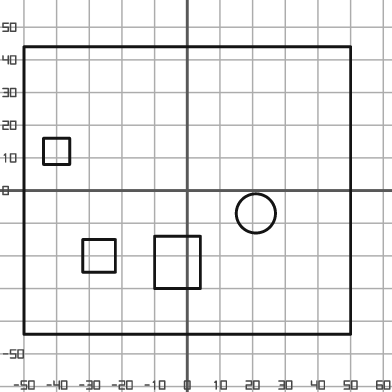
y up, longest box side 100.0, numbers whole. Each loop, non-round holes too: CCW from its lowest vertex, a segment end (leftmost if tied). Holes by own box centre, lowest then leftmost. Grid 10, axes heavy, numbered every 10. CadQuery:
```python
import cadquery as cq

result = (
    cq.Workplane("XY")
    .moveTo(-50.0, -44.0)
    .lineTo(50.0, -44.0)
    .lineTo(50.0, 44.0)
    .lineTo(-50.0, 44.0)
    .close()
    .moveTo(-10.0, -30.0)
    .lineTo(4.0, -30.0)
    .lineTo(4.0, -14.0)
    .lineTo(-10.0, -14.0)
    .close()
    .moveTo(-32.0, -25.0)
    .lineTo(-22.0, -25.0)
    .lineTo(-22.0, -15.0)
    .lineTo(-32.0, -15.0)
    .close()
    .moveTo(21.0, -7.0)
    .circle(6.0)
    .moveTo(-44.0, 8.0)
    .lineTo(-36.0, 8.0)
    .lineTo(-36.0, 16.0)
    .lineTo(-44.0, 16.0)
    .close()
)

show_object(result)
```